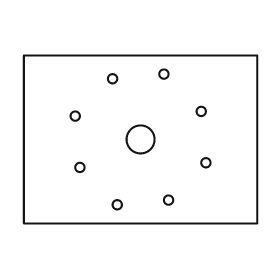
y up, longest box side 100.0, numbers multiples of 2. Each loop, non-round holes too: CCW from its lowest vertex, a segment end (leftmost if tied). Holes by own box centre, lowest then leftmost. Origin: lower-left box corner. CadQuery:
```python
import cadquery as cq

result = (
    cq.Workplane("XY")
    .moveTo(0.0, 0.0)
    .lineTo(100.0, 0.0)
    .lineTo(100.0, 72.0)
    .lineTo(0.0, 72.0)
    .close()
    .moveTo(40.0, 8.0)
    .circle(2.0)
    .moveTo(62.0, 10.0)
    .circle(2.0)
    .moveTo(24.0, 24.0)
    .circle(2.0)
    .moveTo(78.0, 26.0)
    .circle(2.0)
    .moveTo(50.0, 36.0)
    .circle(6.0)
    .moveTo(22.0, 46.0)
    .circle(2.0)
    .moveTo(76.0, 48.0)
    .circle(2.0)
    .moveTo(38.0, 62.0)
    .circle(2.0)
    .moveTo(60.0, 64.0)
    .circle(2.0)
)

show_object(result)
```